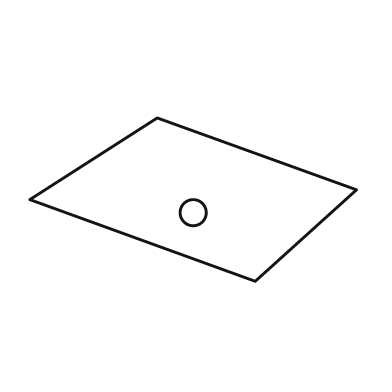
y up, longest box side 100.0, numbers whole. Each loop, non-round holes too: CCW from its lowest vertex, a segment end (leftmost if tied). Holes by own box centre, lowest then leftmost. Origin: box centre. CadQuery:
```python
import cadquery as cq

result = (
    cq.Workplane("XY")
    .moveTo(19.0, -25.0)
    .lineTo(50.0, 3.0)
    .lineTo(-11.0, 25.0)
    .lineTo(-50.0, 0.0)
    .close()
    .moveTo(0.0, -4.0)
    .circle(4.0)
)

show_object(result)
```